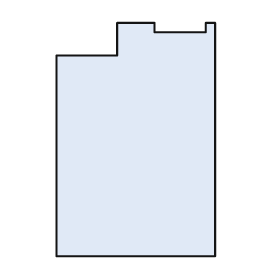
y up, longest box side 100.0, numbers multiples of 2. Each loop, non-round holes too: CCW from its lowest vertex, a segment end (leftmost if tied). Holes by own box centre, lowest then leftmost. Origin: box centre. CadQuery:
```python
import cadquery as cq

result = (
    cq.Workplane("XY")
    .moveTo(-34.0, -50.0)
    .lineTo(34.0, -50.0)
    .lineTo(34.0, 50.0)
    .lineTo(30.0, 50.0)
    .lineTo(30.0, 46.0)
    .lineTo(8.0, 46.0)
    .lineTo(8.0, 50.0)
    .lineTo(-8.0, 50.0)
    .lineTo(-8.0, 36.0)
    .lineTo(-34.0, 36.0)
    .close()
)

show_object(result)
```